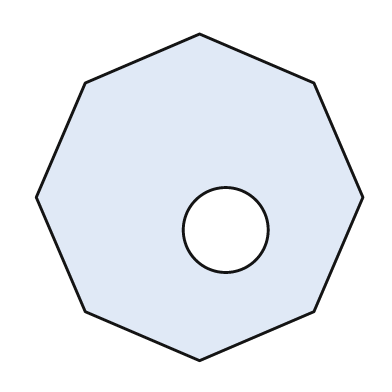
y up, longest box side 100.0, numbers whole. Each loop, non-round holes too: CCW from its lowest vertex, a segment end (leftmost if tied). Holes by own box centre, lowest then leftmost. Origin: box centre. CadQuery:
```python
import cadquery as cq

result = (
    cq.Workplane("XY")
    .moveTo(0.0, -50.0)
    .lineTo(35.0, -35.0)
    .lineTo(50.0, 0.0)
    .lineTo(35.0, 35.0)
    .lineTo(0.0, 50.0)
    .lineTo(-35.0, 35.0)
    .lineTo(-50.0, 0.0)
    .lineTo(-35.0, -35.0)
    .close()
    .moveTo(8.0, -10.0)
    .circle(13.0)
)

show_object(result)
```